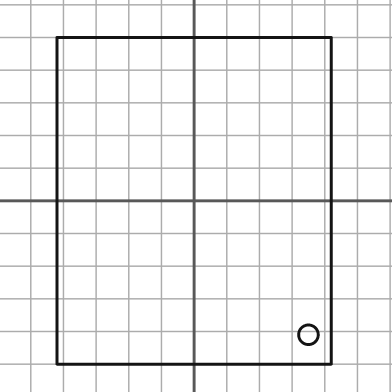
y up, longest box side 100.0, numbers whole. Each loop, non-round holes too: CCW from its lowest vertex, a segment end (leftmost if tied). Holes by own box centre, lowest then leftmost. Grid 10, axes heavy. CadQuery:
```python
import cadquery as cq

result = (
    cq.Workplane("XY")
    .moveTo(-42.0, -50.0)
    .lineTo(42.0, -50.0)
    .lineTo(42.0, 50.0)
    .lineTo(-42.0, 50.0)
    .close()
    .moveTo(35.0, -41.0)
    .circle(3.0)
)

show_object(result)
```